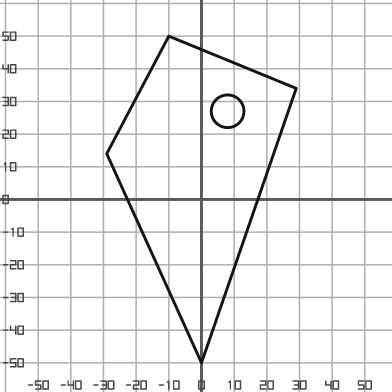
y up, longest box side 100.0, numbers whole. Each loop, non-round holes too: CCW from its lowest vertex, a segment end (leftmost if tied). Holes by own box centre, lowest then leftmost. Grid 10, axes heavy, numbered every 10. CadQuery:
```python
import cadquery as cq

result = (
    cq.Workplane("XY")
    .moveTo(0.0, -50.0)
    .lineTo(29.0, 34.0)
    .lineTo(-10.0, 50.0)
    .lineTo(-29.0, 14.0)
    .close()
    .moveTo(8.0, 27.0)
    .circle(5.0)
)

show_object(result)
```